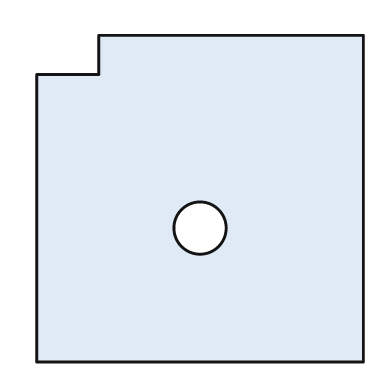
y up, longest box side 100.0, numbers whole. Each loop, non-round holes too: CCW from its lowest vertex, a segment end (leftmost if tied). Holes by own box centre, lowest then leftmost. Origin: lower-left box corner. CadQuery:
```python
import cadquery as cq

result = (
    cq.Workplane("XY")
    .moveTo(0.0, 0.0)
    .lineTo(100.0, 0.0)
    .lineTo(100.0, 100.0)
    .lineTo(19.0, 100.0)
    .lineTo(19.0, 88.0)
    .lineTo(0.0, 88.0)
    .close()
    .moveTo(50.0, 41.0)
    .circle(8.0)
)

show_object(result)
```